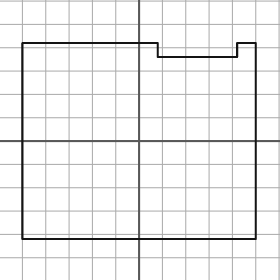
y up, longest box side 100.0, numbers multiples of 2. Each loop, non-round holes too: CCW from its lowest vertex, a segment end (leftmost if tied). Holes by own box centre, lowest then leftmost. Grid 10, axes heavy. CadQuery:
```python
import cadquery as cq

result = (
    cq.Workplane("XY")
    .moveTo(-50.0, -42.0)
    .lineTo(50.0, -42.0)
    .lineTo(50.0, 42.0)
    .lineTo(42.0, 42.0)
    .lineTo(42.0, 36.0)
    .lineTo(8.0, 36.0)
    .lineTo(8.0, 42.0)
    .lineTo(-50.0, 42.0)
    .close()
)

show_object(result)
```